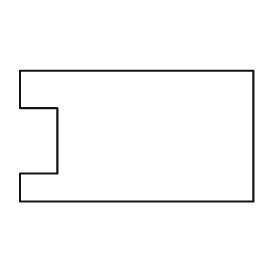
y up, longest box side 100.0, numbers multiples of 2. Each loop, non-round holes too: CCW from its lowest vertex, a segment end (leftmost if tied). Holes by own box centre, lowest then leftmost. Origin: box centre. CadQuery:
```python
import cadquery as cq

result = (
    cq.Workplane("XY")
    .moveTo(-50.0, -28.0)
    .lineTo(50.0, -28.0)
    .lineTo(50.0, 28.0)
    .lineTo(-50.0, 28.0)
    .lineTo(-50.0, 12.0)
    .lineTo(-34.0, 12.0)
    .lineTo(-34.0, -16.0)
    .lineTo(-50.0, -16.0)
    .close()
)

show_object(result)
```